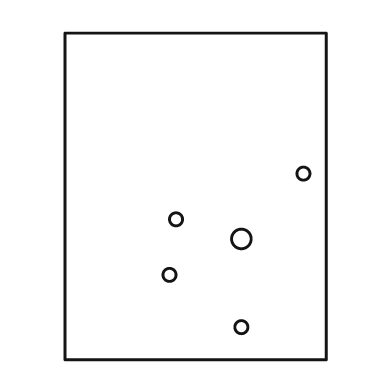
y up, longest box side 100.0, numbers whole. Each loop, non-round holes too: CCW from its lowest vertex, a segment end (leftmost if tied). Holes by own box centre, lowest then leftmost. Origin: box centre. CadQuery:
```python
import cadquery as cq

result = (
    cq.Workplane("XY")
    .moveTo(-40.0, -50.0)
    .lineTo(40.0, -50.0)
    .lineTo(40.0, 50.0)
    .lineTo(-40.0, 50.0)
    .close()
    .moveTo(14.0, -40.0)
    .circle(2.0)
    .moveTo(-8.0, -24.0)
    .circle(2.0)
    .moveTo(14.0, -13.0)
    .circle(3.0)
    .moveTo(-6.0, -7.0)
    .circle(2.0)
    .moveTo(33.0, 7.0)
    .circle(2.0)
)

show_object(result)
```